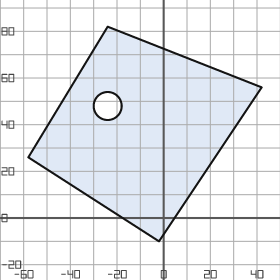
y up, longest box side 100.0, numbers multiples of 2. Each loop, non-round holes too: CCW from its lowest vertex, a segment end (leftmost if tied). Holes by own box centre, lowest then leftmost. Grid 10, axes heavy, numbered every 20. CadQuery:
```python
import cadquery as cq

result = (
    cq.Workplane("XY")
    .moveTo(-2.0, -10.0)
    .lineTo(42.0, 56.0)
    .lineTo(-24.0, 82.0)
    .lineTo(-58.0, 26.0)
    .close()
    .moveTo(-24.0, 48.0)
    .circle(6.0)
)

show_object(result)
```